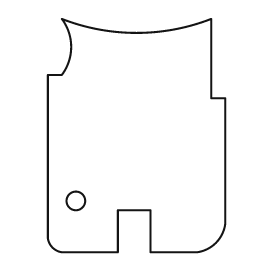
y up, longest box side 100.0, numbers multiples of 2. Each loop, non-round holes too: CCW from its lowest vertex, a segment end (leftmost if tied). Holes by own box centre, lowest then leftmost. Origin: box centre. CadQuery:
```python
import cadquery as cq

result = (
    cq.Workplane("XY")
    .moveTo(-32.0, -50.0)
    .lineTo(-8.0, -50.0)
    .lineTo(-8.0, -32.0)
    .lineTo(6.0, -32.0)
    .lineTo(6.0, -50.0)
    .lineTo(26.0, -50.0)
    .threePointArc((34.0, -46.0), (38.0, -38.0))
    .lineTo(38.0, 16.0)
    .lineTo(32.0, 16.0)
    .lineTo(32.0, 50.0)
    .threePointArc((0.0, 44.0), (-32.0, 50.0))
    .threePointArc((-28.0, 38.0), (-32.0, 26.0))
    .lineTo(-38.0, 26.0)
    .lineTo(-38.0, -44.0)
    .threePointArc((-36.0, -48.0), (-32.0, -50.0))
    .close()
    .moveTo(-26.0, -28.0)
    .circle(4.0)
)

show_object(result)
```